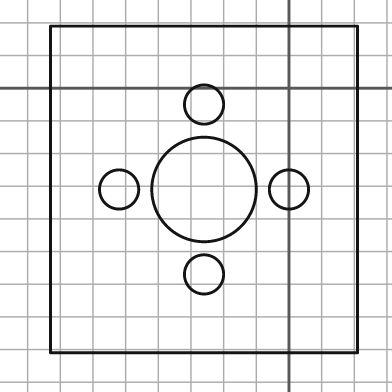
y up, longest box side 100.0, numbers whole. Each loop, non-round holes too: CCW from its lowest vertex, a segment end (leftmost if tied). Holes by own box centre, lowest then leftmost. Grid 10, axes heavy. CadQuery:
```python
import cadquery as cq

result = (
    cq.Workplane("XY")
    .moveTo(-73.0, -81.0)
    .lineTo(21.0, -81.0)
    .lineTo(21.0, 19.0)
    .lineTo(-73.0, 19.0)
    .close()
    .moveTo(-26.0, -57.0)
    .circle(6.0)
    .moveTo(-52.0, -31.0)
    .circle(6.0)
    .moveTo(-26.0, -31.0)
    .circle(16.0)
    .moveTo(0.0, -31.0)
    .circle(6.0)
    .moveTo(-26.0, -5.0)
    .circle(6.0)
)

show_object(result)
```